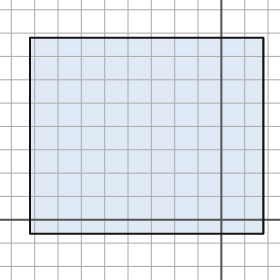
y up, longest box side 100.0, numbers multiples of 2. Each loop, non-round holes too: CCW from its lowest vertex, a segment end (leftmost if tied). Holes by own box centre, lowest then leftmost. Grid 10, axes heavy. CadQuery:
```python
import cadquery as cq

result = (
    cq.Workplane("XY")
    .moveTo(-82.0, -6.0)
    .lineTo(18.0, -6.0)
    .lineTo(18.0, 78.0)
    .lineTo(-82.0, 78.0)
    .close()
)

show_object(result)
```